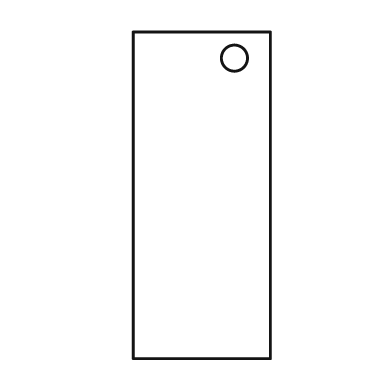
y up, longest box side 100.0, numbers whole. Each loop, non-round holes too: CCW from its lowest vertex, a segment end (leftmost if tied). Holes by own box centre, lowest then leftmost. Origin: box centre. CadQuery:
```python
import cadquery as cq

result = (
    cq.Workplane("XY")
    .moveTo(-21.0, -50.0)
    .lineTo(21.0, -50.0)
    .lineTo(21.0, 50.0)
    .lineTo(-21.0, 50.0)
    .close()
    .moveTo(10.0, 42.0)
    .circle(4.0)
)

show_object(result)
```